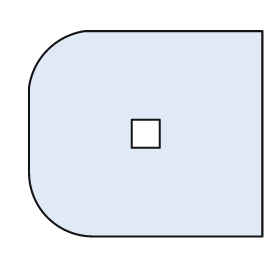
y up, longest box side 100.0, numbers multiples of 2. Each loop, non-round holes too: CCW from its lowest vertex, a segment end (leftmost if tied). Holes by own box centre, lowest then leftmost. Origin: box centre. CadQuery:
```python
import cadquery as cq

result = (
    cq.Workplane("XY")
    .moveTo(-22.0, -44.0)
    .lineTo(50.0, -44.0)
    .lineTo(50.0, 44.0)
    .lineTo(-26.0, 44.0)
    .threePointArc((-42.0, 36.0), (-50.0, 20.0))
    .lineTo(-50.0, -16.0)
    .threePointArc((-42.0, -36.0), (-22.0, -44.0))
    .close()
    .moveTo(-6.0, -6.0)
    .lineTo(6.0, -6.0)
    .lineTo(6.0, 6.0)
    .lineTo(-6.0, 6.0)
    .close()
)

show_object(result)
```